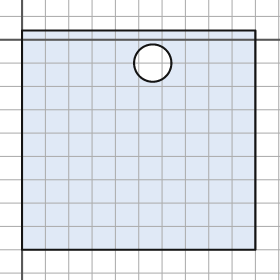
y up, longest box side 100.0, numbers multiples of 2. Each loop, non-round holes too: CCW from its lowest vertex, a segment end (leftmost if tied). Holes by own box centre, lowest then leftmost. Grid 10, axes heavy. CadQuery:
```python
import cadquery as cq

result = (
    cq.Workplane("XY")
    .moveTo(0.0, -90.0)
    .lineTo(100.0, -90.0)
    .lineTo(100.0, 4.0)
    .lineTo(0.0, 4.0)
    .close()
    .moveTo(56.0, -10.0)
    .circle(8.0)
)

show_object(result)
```